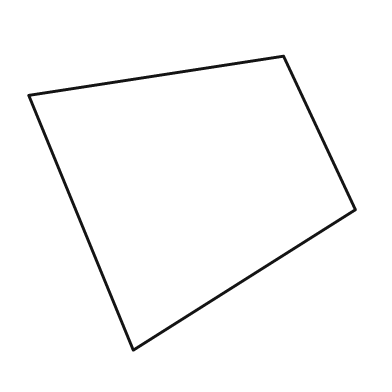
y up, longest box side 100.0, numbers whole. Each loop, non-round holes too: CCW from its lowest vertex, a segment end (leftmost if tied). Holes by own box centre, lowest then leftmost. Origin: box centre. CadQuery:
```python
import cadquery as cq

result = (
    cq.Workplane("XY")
    .moveTo(-18.0, -45.0)
    .lineTo(50.0, -2.0)
    .lineTo(28.0, 45.0)
    .lineTo(-50.0, 33.0)
    .close()
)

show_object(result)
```